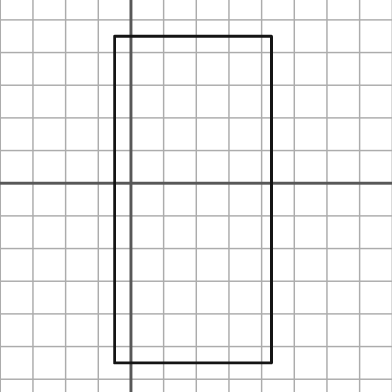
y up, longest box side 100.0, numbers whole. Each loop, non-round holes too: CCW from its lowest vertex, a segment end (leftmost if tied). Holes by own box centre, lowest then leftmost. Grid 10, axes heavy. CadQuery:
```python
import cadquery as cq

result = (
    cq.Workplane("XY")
    .moveTo(-5.0, -55.0)
    .lineTo(43.0, -55.0)
    .lineTo(43.0, 45.0)
    .lineTo(-5.0, 45.0)
    .close()
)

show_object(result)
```